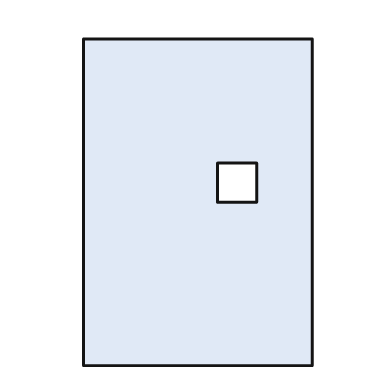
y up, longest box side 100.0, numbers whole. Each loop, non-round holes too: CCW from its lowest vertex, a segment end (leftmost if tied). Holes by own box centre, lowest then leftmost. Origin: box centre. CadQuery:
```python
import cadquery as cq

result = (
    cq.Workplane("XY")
    .moveTo(-35.0, -50.0)
    .lineTo(35.0, -50.0)
    .lineTo(35.0, 50.0)
    .lineTo(-35.0, 50.0)
    .close()
    .moveTo(6.0, 0.0)
    .lineTo(18.0, 0.0)
    .lineTo(18.0, 12.0)
    .lineTo(6.0, 12.0)
    .close()
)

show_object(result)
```